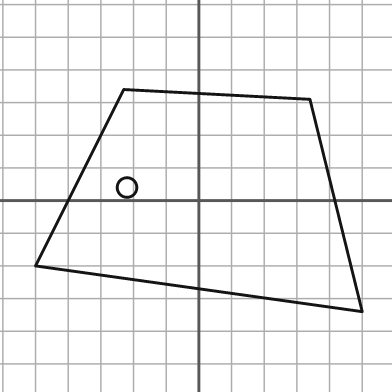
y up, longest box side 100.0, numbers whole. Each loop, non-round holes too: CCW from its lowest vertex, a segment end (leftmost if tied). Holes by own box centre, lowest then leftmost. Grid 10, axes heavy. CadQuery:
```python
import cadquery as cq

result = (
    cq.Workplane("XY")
    .moveTo(50.0, -34.0)
    .lineTo(34.0, 31.0)
    .lineTo(-23.0, 34.0)
    .lineTo(-50.0, -20.0)
    .close()
    .moveTo(-22.0, 4.0)
    .circle(3.0)
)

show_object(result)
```